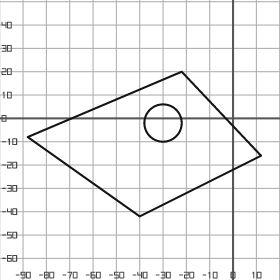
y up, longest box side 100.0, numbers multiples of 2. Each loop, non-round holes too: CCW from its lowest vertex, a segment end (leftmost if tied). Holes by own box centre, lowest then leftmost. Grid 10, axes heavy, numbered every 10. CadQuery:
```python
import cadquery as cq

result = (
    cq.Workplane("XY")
    .moveTo(-40.0, -42.0)
    .lineTo(12.0, -16.0)
    .lineTo(-22.0, 20.0)
    .lineTo(-88.0, -8.0)
    .close()
    .moveTo(-30.0, -2.0)
    .circle(8.0)
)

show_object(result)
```